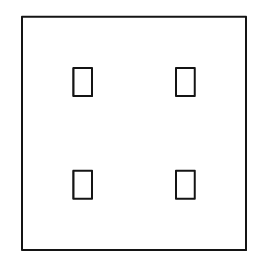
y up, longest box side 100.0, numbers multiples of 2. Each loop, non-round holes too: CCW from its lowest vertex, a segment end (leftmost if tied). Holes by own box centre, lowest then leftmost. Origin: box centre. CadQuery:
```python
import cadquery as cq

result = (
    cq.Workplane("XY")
    .moveTo(-48.0, -50.0)
    .lineTo(48.0, -50.0)
    .lineTo(48.0, 50.0)
    .lineTo(-48.0, 50.0)
    .close()
    .moveTo(-26.0, -28.0)
    .lineTo(-18.0, -28.0)
    .lineTo(-18.0, -16.0)
    .lineTo(-26.0, -16.0)
    .close()
    .moveTo(18.0, -28.0)
    .lineTo(26.0, -28.0)
    .lineTo(26.0, -16.0)
    .lineTo(18.0, -16.0)
    .close()
    .moveTo(-26.0, 16.0)
    .lineTo(-18.0, 16.0)
    .lineTo(-18.0, 28.0)
    .lineTo(-26.0, 28.0)
    .close()
    .moveTo(18.0, 16.0)
    .lineTo(26.0, 16.0)
    .lineTo(26.0, 28.0)
    .lineTo(18.0, 28.0)
    .close()
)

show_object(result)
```